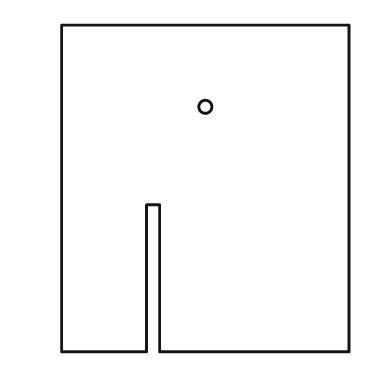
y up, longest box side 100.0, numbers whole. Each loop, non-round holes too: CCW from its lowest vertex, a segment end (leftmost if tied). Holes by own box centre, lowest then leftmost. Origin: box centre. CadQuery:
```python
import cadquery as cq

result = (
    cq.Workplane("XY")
    .moveTo(-44.0, -50.0)
    .lineTo(-18.0, -50.0)
    .lineTo(-18.0, -5.0)
    .lineTo(-14.0, -5.0)
    .lineTo(-14.0, -50.0)
    .lineTo(44.0, -50.0)
    .lineTo(44.0, 50.0)
    .lineTo(-44.0, 50.0)
    .close()
    .moveTo(0.0, 25.0)
    .circle(2.0)
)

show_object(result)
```